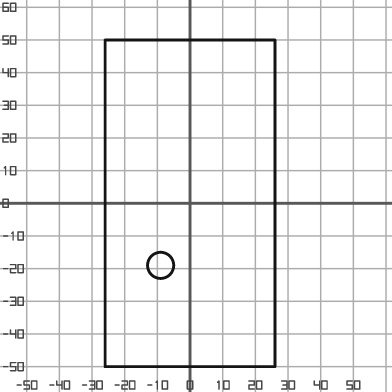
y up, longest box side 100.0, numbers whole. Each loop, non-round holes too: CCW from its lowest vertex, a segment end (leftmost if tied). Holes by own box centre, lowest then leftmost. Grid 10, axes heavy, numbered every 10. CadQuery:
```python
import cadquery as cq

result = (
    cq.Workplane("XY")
    .moveTo(-26.0, -50.0)
    .lineTo(26.0, -50.0)
    .lineTo(26.0, 50.0)
    .lineTo(-26.0, 50.0)
    .close()
    .moveTo(-9.0, -19.0)
    .circle(4.0)
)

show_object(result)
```